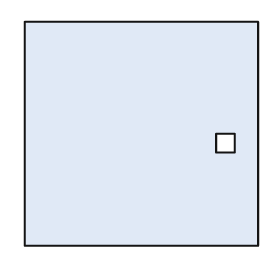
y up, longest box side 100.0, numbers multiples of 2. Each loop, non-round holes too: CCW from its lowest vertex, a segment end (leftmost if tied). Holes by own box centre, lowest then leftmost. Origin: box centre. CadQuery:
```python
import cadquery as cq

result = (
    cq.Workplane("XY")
    .moveTo(-50.0, -48.0)
    .lineTo(50.0, -48.0)
    .lineTo(50.0, 48.0)
    .lineTo(-50.0, 48.0)
    .close()
    .moveTo(32.0, -8.0)
    .lineTo(40.0, -8.0)
    .lineTo(40.0, 0.0)
    .lineTo(32.0, 0.0)
    .close()
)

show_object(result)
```